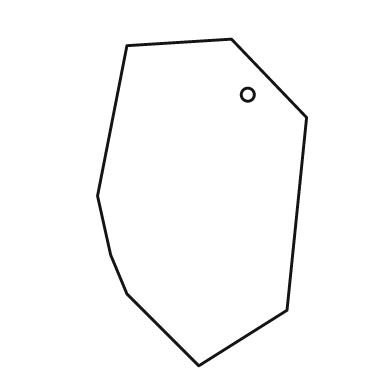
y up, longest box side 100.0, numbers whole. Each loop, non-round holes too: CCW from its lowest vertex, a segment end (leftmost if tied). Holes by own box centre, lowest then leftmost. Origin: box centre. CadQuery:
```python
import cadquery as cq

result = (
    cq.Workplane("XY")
    .moveTo(-1.0, -50.0)
    .lineTo(26.0, -33.0)
    .lineTo(32.0, 26.0)
    .lineTo(9.0, 50.0)
    .lineTo(-23.0, 48.0)
    .lineTo(-32.0, 2.0)
    .lineTo(-28.0, -16.0)
    .lineTo(-23.0, -28.0)
    .close()
    .moveTo(14.0, 33.0)
    .circle(2.0)
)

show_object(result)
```